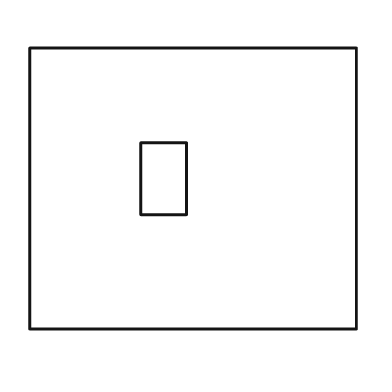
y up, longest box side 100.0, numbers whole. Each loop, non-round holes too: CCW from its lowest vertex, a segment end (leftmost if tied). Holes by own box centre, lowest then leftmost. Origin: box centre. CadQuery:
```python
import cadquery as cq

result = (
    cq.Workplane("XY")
    .moveTo(-50.0, -43.0)
    .lineTo(50.0, -43.0)
    .lineTo(50.0, 43.0)
    .lineTo(-50.0, 43.0)
    .close()
    .moveTo(-16.0, -8.0)
    .lineTo(-2.0, -8.0)
    .lineTo(-2.0, 14.0)
    .lineTo(-16.0, 14.0)
    .close()
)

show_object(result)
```